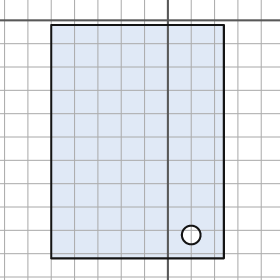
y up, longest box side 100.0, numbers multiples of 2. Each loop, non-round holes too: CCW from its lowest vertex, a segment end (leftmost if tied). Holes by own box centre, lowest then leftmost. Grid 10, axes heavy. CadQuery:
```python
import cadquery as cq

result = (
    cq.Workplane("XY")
    .moveTo(-50.0, -102.0)
    .lineTo(24.0, -102.0)
    .lineTo(24.0, -2.0)
    .lineTo(-50.0, -2.0)
    .close()
    .moveTo(10.0, -92.0)
    .circle(4.0)
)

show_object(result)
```